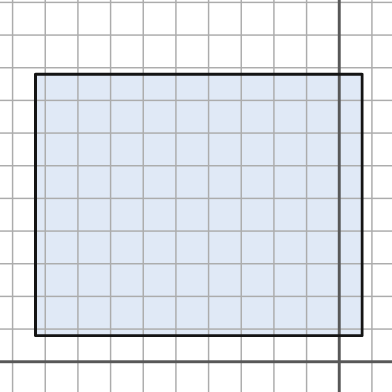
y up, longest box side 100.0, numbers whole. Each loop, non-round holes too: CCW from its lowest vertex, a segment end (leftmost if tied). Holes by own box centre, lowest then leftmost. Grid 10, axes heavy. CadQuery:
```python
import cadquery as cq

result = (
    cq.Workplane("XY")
    .moveTo(-93.0, 8.0)
    .lineTo(7.0, 8.0)
    .lineTo(7.0, 88.0)
    .lineTo(-93.0, 88.0)
    .close()
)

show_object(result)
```